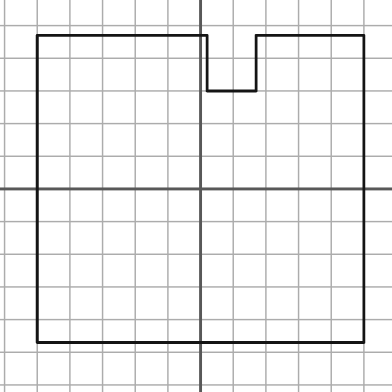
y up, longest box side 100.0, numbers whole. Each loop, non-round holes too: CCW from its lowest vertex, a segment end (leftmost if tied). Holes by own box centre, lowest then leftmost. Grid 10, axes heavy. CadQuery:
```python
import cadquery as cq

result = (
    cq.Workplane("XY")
    .moveTo(-50.0, -47.0)
    .lineTo(50.0, -47.0)
    .lineTo(50.0, 47.0)
    .lineTo(17.0, 47.0)
    .lineTo(17.0, 30.0)
    .lineTo(2.0, 30.0)
    .lineTo(2.0, 47.0)
    .lineTo(-50.0, 47.0)
    .close()
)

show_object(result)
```